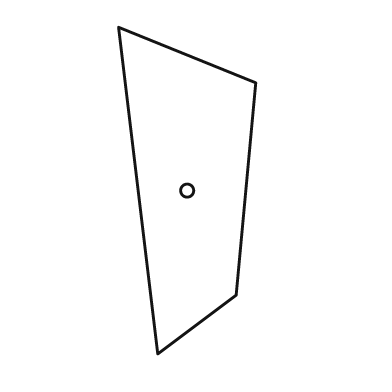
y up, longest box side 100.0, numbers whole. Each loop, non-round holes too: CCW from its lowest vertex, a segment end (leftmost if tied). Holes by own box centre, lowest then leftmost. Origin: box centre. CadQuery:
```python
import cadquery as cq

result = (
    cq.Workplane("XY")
    .moveTo(-9.0, -50.0)
    .lineTo(15.0, -32.0)
    .lineTo(21.0, 33.0)
    .lineTo(-21.0, 50.0)
    .close()
    .moveTo(0.0, 0.0)
    .circle(2.0)
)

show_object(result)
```